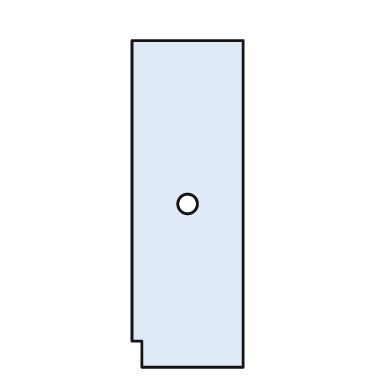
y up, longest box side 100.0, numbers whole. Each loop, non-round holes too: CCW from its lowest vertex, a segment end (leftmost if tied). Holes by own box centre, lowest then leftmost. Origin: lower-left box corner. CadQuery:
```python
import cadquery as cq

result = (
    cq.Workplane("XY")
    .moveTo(3.0, 0.0)
    .lineTo(34.0, 0.0)
    .lineTo(34.0, 100.0)
    .lineTo(0.0, 100.0)
    .lineTo(0.0, 8.0)
    .lineTo(3.0, 8.0)
    .close()
    .moveTo(17.0, 50.0)
    .circle(3.0)
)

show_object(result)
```